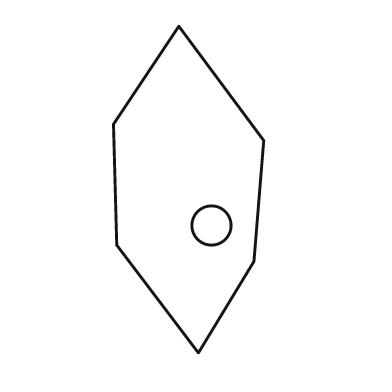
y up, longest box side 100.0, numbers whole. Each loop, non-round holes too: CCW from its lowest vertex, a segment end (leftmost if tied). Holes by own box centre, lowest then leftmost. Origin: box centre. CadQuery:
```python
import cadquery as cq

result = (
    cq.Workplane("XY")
    .moveTo(3.0, -50.0)
    .lineTo(20.0, -22.0)
    .lineTo(23.0, 15.0)
    .lineTo(-3.0, 50.0)
    .lineTo(-23.0, 20.0)
    .lineTo(-22.0, -17.0)
    .close()
    .moveTo(7.0, -11.0)
    .circle(6.0)
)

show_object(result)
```